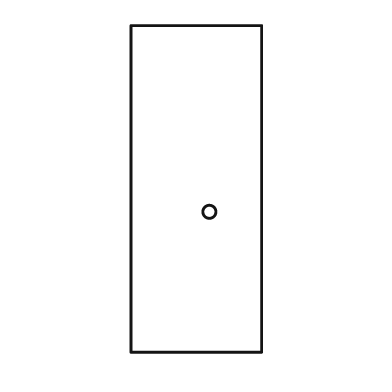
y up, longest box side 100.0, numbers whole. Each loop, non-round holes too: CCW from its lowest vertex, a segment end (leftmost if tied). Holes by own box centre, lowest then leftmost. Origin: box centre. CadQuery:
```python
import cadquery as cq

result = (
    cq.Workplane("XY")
    .moveTo(-20.0, -50.0)
    .lineTo(20.0, -50.0)
    .lineTo(20.0, 50.0)
    .lineTo(-20.0, 50.0)
    .close()
    .moveTo(4.0, -7.0)
    .circle(2.0)
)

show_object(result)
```